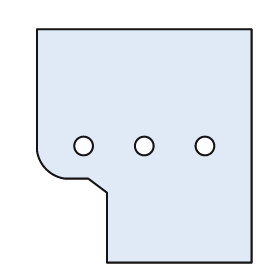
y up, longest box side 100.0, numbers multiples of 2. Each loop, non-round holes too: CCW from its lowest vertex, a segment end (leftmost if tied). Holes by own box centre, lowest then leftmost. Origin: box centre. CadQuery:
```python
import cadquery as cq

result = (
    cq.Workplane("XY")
    .moveTo(-16.0, -50.0)
    .lineTo(46.0, -50.0)
    .lineTo(46.0, 50.0)
    .lineTo(-46.0, 50.0)
    .lineTo(-46.0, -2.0)
    .threePointArc((-42.0, -10.0), (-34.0, -14.0))
    .lineTo(-24.0, -14.0)
    .lineTo(-16.0, -20.0)
    .close()
    .moveTo(-26.0, 0.0)
    .circle(4.0)
    .moveTo(0.0, 0.0)
    .circle(4.0)
    .moveTo(26.0, 0.0)
    .circle(4.0)
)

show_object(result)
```